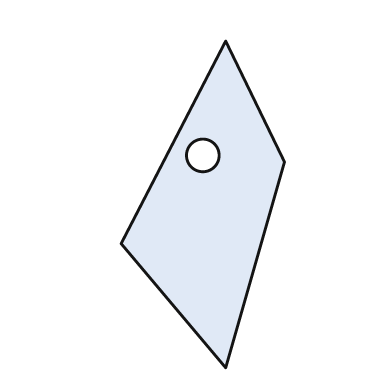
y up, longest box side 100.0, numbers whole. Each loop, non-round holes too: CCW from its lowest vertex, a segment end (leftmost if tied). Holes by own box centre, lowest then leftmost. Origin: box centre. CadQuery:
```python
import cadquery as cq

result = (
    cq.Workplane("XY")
    .moveTo(7.0, -50.0)
    .lineTo(25.0, 13.0)
    .lineTo(7.0, 50.0)
    .lineTo(-25.0, -12.0)
    .close()
    .moveTo(0.0, 15.0)
    .circle(5.0)
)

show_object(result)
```